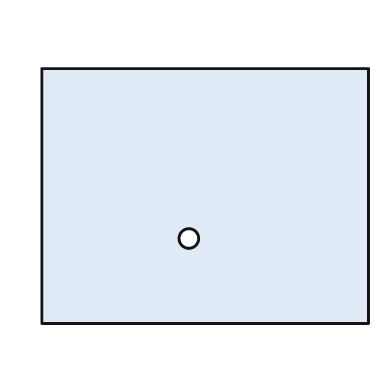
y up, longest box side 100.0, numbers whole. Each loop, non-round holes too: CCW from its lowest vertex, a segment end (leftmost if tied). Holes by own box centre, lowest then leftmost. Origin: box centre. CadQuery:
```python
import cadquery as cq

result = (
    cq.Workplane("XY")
    .moveTo(-50.0, -39.0)
    .lineTo(50.0, -39.0)
    .lineTo(50.0, 39.0)
    .lineTo(-50.0, 39.0)
    .close()
    .moveTo(-5.0, -13.0)
    .circle(3.0)
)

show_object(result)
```